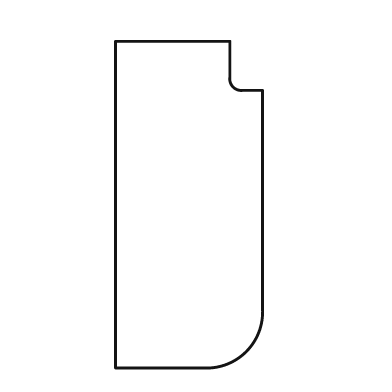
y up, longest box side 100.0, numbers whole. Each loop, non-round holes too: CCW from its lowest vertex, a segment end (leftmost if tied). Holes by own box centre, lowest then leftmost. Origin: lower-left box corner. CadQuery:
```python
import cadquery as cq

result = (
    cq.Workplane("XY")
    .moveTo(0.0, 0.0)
    .lineTo(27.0, 0.0)
    .threePointArc((40.0, 5.0), (45.0, 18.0))
    .lineTo(45.0, 85.0)
    .lineTo(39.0, 85.0)
    .threePointArc((36.0, 86.0), (35.0, 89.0))
    .lineTo(35.0, 100.0)
    .lineTo(0.0, 100.0)
    .close()
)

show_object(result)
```